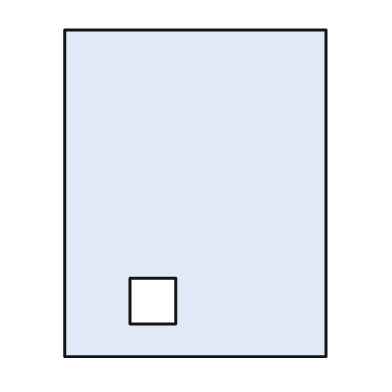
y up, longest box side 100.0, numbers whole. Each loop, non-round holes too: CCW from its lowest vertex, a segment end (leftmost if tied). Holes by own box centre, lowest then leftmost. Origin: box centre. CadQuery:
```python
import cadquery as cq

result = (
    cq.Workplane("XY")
    .moveTo(-40.0, -50.0)
    .lineTo(40.0, -50.0)
    .lineTo(40.0, 50.0)
    .lineTo(-40.0, 50.0)
    .close()
    .moveTo(-20.0, -40.0)
    .lineTo(-6.0, -40.0)
    .lineTo(-6.0, -26.0)
    .lineTo(-20.0, -26.0)
    .close()
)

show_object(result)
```